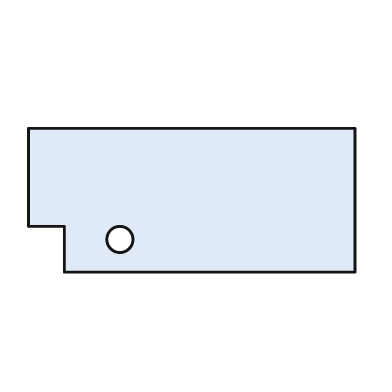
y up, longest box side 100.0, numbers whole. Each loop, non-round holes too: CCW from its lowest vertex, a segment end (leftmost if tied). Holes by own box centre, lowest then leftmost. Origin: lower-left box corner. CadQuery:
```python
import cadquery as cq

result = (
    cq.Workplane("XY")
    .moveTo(11.0, 0.0)
    .lineTo(100.0, 0.0)
    .lineTo(100.0, 44.0)
    .lineTo(0.0, 44.0)
    .lineTo(0.0, 14.0)
    .lineTo(11.0, 14.0)
    .close()
    .moveTo(28.0, 10.0)
    .circle(4.0)
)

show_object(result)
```